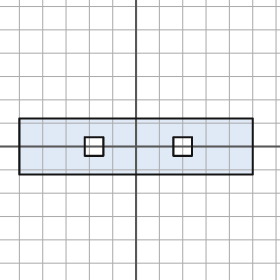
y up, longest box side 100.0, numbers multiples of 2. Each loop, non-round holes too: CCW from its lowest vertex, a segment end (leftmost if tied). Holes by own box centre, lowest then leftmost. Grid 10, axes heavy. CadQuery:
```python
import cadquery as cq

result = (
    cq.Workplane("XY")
    .moveTo(-50.0, -12.0)
    .lineTo(50.0, -12.0)
    .lineTo(50.0, 12.0)
    .lineTo(-50.0, 12.0)
    .close()
    .moveTo(-22.0, -4.0)
    .lineTo(-14.0, -4.0)
    .lineTo(-14.0, 4.0)
    .lineTo(-22.0, 4.0)
    .close()
    .moveTo(16.0, -4.0)
    .lineTo(24.0, -4.0)
    .lineTo(24.0, 4.0)
    .lineTo(16.0, 4.0)
    .close()
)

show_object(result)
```